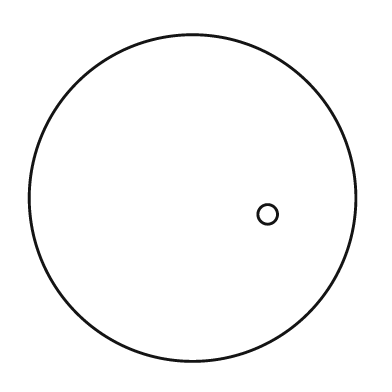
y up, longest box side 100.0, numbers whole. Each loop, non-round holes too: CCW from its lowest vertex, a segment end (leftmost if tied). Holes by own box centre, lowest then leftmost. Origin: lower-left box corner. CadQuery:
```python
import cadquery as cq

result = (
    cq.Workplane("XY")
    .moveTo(50.0, 50.0)
    .circle(50.0)
    .moveTo(73.0, 45.0)
    .circle(3.0)
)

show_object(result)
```